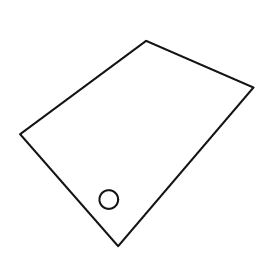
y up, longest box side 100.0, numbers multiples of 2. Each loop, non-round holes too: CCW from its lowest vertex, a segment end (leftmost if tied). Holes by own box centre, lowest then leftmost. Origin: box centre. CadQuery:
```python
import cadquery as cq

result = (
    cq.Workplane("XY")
    .moveTo(-8.0, -44.0)
    .lineTo(50.0, 24.0)
    .lineTo(4.0, 44.0)
    .lineTo(-50.0, 4.0)
    .close()
    .moveTo(-12.0, -24.0)
    .circle(4.0)
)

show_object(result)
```